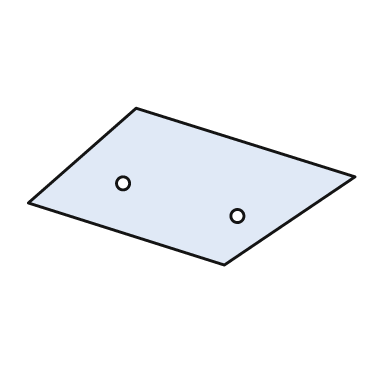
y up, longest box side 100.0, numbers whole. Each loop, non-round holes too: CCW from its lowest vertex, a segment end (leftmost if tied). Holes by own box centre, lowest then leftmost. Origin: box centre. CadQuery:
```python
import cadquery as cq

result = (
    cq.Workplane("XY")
    .moveTo(10.0, -24.0)
    .lineTo(50.0, 3.0)
    .lineTo(-17.0, 24.0)
    .lineTo(-50.0, -5.0)
    .close()
    .moveTo(14.0, -9.0)
    .circle(2.0)
    .moveTo(-21.0, 1.0)
    .circle(2.0)
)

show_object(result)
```